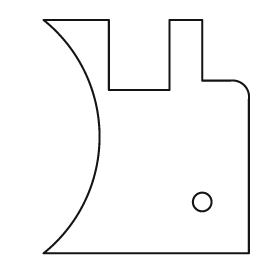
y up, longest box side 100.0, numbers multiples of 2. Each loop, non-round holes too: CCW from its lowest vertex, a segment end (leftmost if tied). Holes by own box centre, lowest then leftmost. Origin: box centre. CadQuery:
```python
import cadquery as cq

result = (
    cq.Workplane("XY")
    .moveTo(-44.0, -50.0)
    .lineTo(44.0, -50.0)
    .lineTo(44.0, 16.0)
    .threePointArc((42.0, 22.0), (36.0, 24.0))
    .lineTo(24.0, 24.0)
    .lineTo(24.0, 50.0)
    .lineTo(10.0, 50.0)
    .lineTo(10.0, 20.0)
    .lineTo(-16.0, 20.0)
    .lineTo(-16.0, 50.0)
    .lineTo(-44.0, 50.0)
    .threePointArc((-20.0, 0.0), (-44.0, -50.0))
    .close()
    .moveTo(24.0, -28.0)
    .circle(4.0)
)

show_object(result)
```